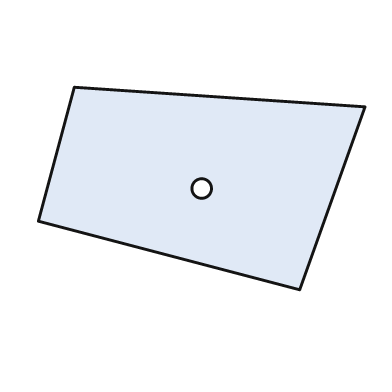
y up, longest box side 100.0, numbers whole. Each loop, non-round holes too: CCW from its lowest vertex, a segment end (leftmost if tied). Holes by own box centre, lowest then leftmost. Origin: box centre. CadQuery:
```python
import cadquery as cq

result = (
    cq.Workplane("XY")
    .moveTo(30.0, -31.0)
    .lineTo(50.0, 25.0)
    .lineTo(-39.0, 31.0)
    .lineTo(-50.0, -10.0)
    .close()
    .moveTo(0.0, 0.0)
    .circle(3.0)
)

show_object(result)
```